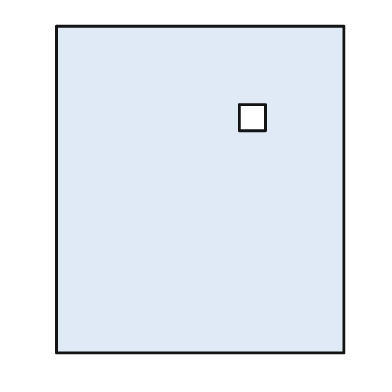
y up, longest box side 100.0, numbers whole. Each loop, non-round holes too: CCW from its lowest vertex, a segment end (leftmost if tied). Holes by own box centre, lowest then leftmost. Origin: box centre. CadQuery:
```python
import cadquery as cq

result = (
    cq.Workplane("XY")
    .moveTo(-44.0, -50.0)
    .lineTo(44.0, -50.0)
    .lineTo(44.0, 50.0)
    .lineTo(-44.0, 50.0)
    .close()
    .moveTo(12.0, 18.0)
    .lineTo(20.0, 18.0)
    .lineTo(20.0, 26.0)
    .lineTo(12.0, 26.0)
    .close()
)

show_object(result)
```